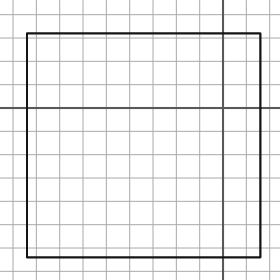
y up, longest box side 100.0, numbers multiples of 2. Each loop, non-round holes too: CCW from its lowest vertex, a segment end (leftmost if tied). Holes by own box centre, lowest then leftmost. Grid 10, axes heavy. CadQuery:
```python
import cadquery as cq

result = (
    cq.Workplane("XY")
    .moveTo(-84.0, -64.0)
    .lineTo(16.0, -64.0)
    .lineTo(16.0, 32.0)
    .lineTo(-84.0, 32.0)
    .close()
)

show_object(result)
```